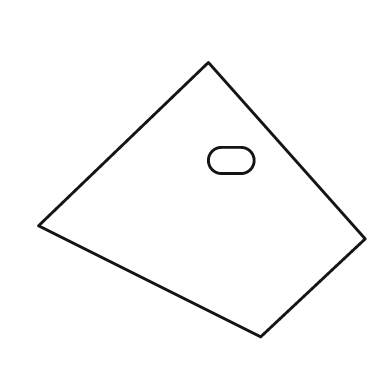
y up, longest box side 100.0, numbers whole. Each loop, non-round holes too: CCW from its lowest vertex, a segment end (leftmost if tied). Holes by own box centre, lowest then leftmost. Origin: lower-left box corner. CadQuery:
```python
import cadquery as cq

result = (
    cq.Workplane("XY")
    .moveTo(68.0, 0.0)
    .lineTo(100.0, 30.0)
    .lineTo(52.0, 84.0)
    .lineTo(0.0, 34.0)
    .close()
    .moveTo(56.0, 50.0)
    .lineTo(62.0, 50.0)
    .threePointArc((66.0, 54.0), (62.0, 58.0))
    .lineTo(56.0, 58.0)
    .threePointArc((52.0, 54.0), (56.0, 50.0))
    .close()
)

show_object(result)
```